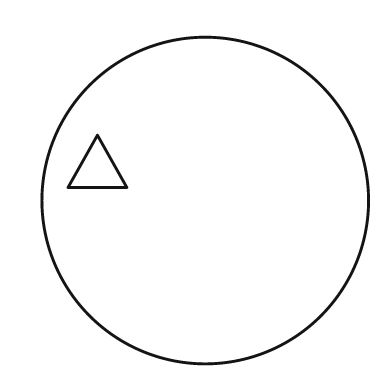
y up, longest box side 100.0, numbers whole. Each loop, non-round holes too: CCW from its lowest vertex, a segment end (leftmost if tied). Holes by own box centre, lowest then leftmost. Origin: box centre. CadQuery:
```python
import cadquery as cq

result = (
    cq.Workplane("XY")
    .moveTo(0.0, 0.0)
    .circle(50.0)
    .moveTo(-42.0, 4.0)
    .lineTo(-24.0, 4.0)
    .lineTo(-33.0, 20.0)
    .close()
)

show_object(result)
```